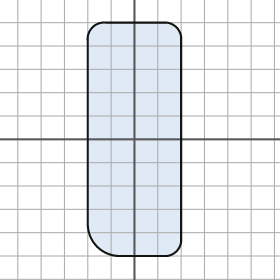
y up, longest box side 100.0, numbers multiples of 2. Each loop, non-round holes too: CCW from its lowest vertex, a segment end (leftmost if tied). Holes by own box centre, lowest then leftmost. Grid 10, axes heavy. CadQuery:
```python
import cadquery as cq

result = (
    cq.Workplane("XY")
    .moveTo(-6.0, -50.0)
    .lineTo(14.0, -50.0)
    .threePointArc((18.0, -48.0), (20.0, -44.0))
    .lineTo(20.0, 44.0)
    .threePointArc((18.0, 48.0), (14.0, 50.0))
    .lineTo(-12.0, 50.0)
    .threePointArc((-18.0, 48.0), (-20.0, 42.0))
    .lineTo(-20.0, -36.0)
    .threePointArc((-16.0, -46.0), (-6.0, -50.0))
    .close()
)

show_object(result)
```